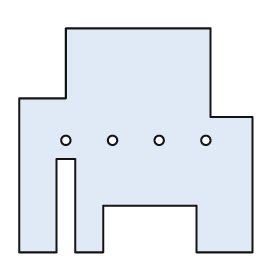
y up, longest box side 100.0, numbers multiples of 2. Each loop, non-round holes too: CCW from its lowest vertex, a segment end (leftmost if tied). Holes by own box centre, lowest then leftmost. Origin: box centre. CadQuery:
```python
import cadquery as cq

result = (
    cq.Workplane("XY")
    .moveTo(-50.0, -48.0)
    .lineTo(-34.0, -48.0)
    .lineTo(-34.0, -8.0)
    .lineTo(-26.0, -8.0)
    .lineTo(-26.0, -48.0)
    .lineTo(-14.0, -48.0)
    .lineTo(-14.0, -28.0)
    .lineTo(26.0, -28.0)
    .lineTo(26.0, -48.0)
    .lineTo(50.0, -48.0)
    .lineTo(50.0, 10.0)
    .lineTo(32.0, 10.0)
    .lineTo(32.0, 48.0)
    .lineTo(-30.0, 48.0)
    .lineTo(-30.0, 18.0)
    .lineTo(-50.0, 18.0)
    .close()
    .moveTo(-30.0, 0.0)
    .circle(2.0)
    .moveTo(-10.0, 0.0)
    .circle(2.0)
    .moveTo(10.0, 0.0)
    .circle(2.0)
    .moveTo(30.0, 0.0)
    .circle(2.0)
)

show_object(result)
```